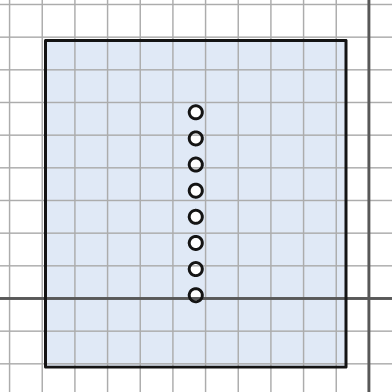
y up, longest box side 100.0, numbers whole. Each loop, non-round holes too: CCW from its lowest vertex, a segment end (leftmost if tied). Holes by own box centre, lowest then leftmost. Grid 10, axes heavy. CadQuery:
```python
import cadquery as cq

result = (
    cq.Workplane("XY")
    .moveTo(-99.0, -21.0)
    .lineTo(-7.0, -21.0)
    .lineTo(-7.0, 79.0)
    .lineTo(-99.0, 79.0)
    .close()
    .moveTo(-53.0, 1.0)
    .circle(2.0)
    .moveTo(-53.0, 9.0)
    .circle(2.0)
    .moveTo(-53.0, 17.0)
    .circle(2.0)
    .moveTo(-53.0, 25.0)
    .circle(2.0)
    .moveTo(-53.0, 33.0)
    .circle(2.0)
    .moveTo(-53.0, 41.0)
    .circle(2.0)
    .moveTo(-53.0, 49.0)
    .circle(2.0)
    .moveTo(-53.0, 57.0)
    .circle(2.0)
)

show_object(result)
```